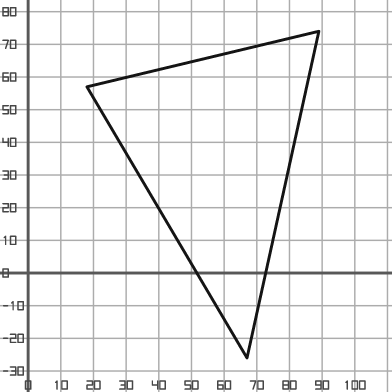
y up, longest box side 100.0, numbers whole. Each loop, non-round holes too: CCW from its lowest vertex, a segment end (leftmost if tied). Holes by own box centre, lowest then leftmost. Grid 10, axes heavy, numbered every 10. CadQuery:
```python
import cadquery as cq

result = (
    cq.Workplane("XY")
    .moveTo(67.0, -26.0)
    .lineTo(89.0, 74.0)
    .lineTo(18.0, 57.0)
    .close()
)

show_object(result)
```